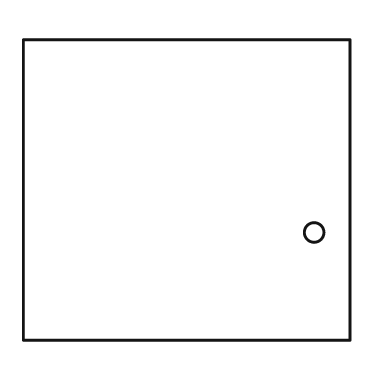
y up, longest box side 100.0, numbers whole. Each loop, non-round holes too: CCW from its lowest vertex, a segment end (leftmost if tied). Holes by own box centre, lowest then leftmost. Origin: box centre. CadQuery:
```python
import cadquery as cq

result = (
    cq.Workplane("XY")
    .moveTo(-50.0, -46.0)
    .lineTo(50.0, -46.0)
    .lineTo(50.0, 46.0)
    .lineTo(-50.0, 46.0)
    .close()
    .moveTo(39.0, -13.0)
    .circle(3.0)
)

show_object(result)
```